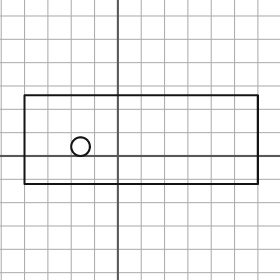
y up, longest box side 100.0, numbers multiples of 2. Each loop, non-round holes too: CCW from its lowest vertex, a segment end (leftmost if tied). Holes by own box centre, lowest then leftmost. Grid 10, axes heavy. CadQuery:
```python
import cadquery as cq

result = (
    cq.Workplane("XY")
    .moveTo(-40.0, -12.0)
    .lineTo(60.0, -12.0)
    .lineTo(60.0, 26.0)
    .lineTo(-40.0, 26.0)
    .close()
    .moveTo(-16.0, 4.0)
    .circle(4.0)
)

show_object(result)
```